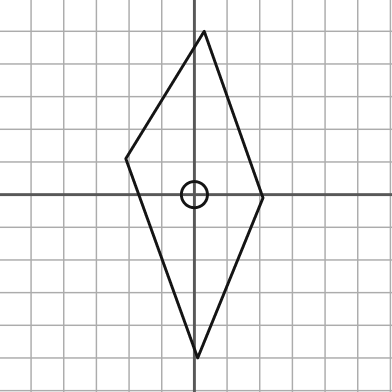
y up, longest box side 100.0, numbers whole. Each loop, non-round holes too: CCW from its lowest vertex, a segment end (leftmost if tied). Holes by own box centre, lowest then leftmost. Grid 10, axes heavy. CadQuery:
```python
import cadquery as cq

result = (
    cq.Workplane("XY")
    .moveTo(1.0, -50.0)
    .lineTo(21.0, -1.0)
    .lineTo(3.0, 50.0)
    .lineTo(-21.0, 11.0)
    .close()
    .moveTo(0.0, 0.0)
    .circle(4.0)
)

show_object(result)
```